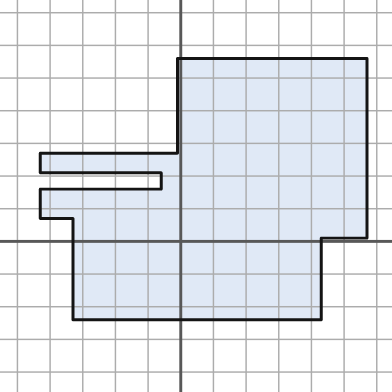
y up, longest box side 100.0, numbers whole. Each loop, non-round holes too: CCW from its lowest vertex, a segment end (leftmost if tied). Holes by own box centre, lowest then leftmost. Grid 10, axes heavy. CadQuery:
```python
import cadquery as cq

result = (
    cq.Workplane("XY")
    .moveTo(-33.0, -24.0)
    .lineTo(43.0, -24.0)
    .lineTo(43.0, 1.0)
    .lineTo(57.0, 1.0)
    .lineTo(57.0, 56.0)
    .lineTo(-1.0, 56.0)
    .lineTo(-1.0, 27.0)
    .lineTo(-43.0, 27.0)
    .lineTo(-43.0, 21.0)
    .lineTo(-6.0, 21.0)
    .lineTo(-6.0, 16.0)
    .lineTo(-43.0, 16.0)
    .lineTo(-43.0, 7.0)
    .lineTo(-33.0, 7.0)
    .close()
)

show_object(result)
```